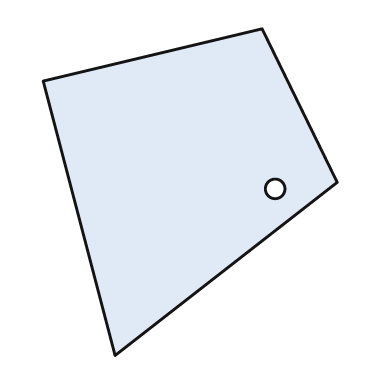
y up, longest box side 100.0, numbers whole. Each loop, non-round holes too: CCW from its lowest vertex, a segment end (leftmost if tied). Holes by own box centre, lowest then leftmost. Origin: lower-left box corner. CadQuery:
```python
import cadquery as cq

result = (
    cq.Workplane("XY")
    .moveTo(22.0, 0.0)
    .lineTo(90.0, 53.0)
    .lineTo(67.0, 100.0)
    .lineTo(0.0, 84.0)
    .close()
    .moveTo(71.0, 51.0)
    .circle(3.0)
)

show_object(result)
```